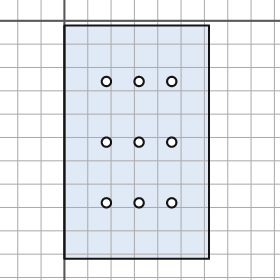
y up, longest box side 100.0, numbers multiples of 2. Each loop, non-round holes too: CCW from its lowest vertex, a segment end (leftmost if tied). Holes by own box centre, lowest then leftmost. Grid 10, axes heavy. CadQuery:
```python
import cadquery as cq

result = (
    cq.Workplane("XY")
    .moveTo(0.0, -102.0)
    .lineTo(62.0, -102.0)
    .lineTo(62.0, -2.0)
    .lineTo(0.0, -2.0)
    .close()
    .moveTo(18.0, -78.0)
    .circle(2.0)
    .moveTo(32.0, -78.0)
    .circle(2.0)
    .moveTo(46.0, -78.0)
    .circle(2.0)
    .moveTo(18.0, -52.0)
    .circle(2.0)
    .moveTo(32.0, -52.0)
    .circle(2.0)
    .moveTo(46.0, -52.0)
    .circle(2.0)
    .moveTo(18.0, -26.0)
    .circle(2.0)
    .moveTo(32.0, -26.0)
    .circle(2.0)
    .moveTo(46.0, -26.0)
    .circle(2.0)
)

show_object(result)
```